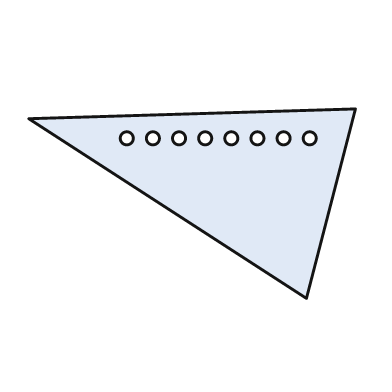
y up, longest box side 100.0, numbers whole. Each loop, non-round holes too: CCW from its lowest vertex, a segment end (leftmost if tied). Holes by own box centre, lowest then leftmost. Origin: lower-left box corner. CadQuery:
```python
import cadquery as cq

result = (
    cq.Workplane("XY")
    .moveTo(85.0, 0.0)
    .lineTo(100.0, 58.0)
    .lineTo(0.0, 55.0)
    .close()
    .moveTo(30.0, 49.0)
    .circle(2.0)
    .moveTo(38.0, 49.0)
    .circle(2.0)
    .moveTo(46.0, 49.0)
    .circle(2.0)
    .moveTo(54.0, 49.0)
    .circle(2.0)
    .moveTo(62.0, 49.0)
    .circle(2.0)
    .moveTo(70.0, 49.0)
    .circle(2.0)
    .moveTo(78.0, 49.0)
    .circle(2.0)
    .moveTo(86.0, 49.0)
    .circle(2.0)
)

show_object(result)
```